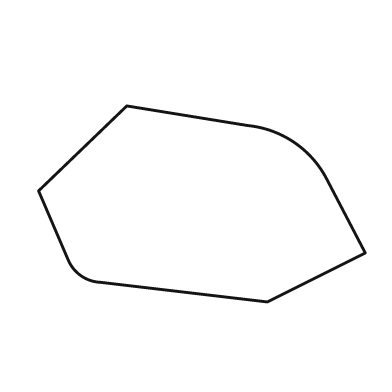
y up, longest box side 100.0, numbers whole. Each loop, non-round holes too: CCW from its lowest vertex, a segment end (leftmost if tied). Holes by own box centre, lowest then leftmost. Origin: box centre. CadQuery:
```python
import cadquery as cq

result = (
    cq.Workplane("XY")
    .moveTo(20.0, -30.0)
    .lineTo(50.0, -15.0)
    .lineTo(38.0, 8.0)
    .threePointArc((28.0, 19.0), (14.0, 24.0))
    .lineTo(-23.0, 30.0)
    .lineTo(-50.0, 4.0)
    .lineTo(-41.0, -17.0)
    .threePointArc((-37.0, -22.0), (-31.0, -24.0))
    .close()
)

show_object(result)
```